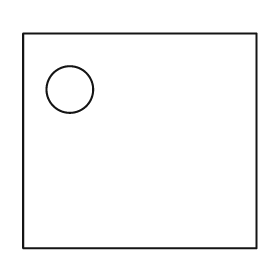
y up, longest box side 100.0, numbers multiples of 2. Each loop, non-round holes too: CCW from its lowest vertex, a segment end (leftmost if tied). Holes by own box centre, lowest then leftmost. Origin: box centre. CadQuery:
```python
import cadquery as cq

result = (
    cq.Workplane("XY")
    .moveTo(-50.0, -46.0)
    .lineTo(50.0, -46.0)
    .lineTo(50.0, 46.0)
    .lineTo(-50.0, 46.0)
    .close()
    .moveTo(-30.0, 22.0)
    .circle(10.0)
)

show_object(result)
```